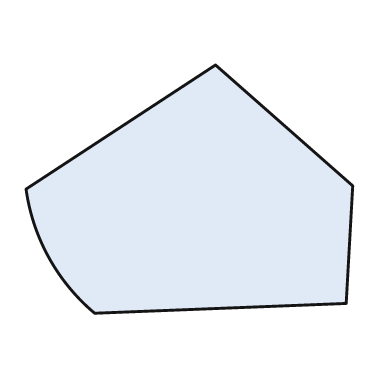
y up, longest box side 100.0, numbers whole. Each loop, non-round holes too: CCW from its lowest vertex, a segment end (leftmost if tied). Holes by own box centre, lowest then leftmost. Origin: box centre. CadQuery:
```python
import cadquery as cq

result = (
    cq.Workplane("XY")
    .moveTo(-29.0, -38.0)
    .lineTo(48.0, -35.0)
    .lineTo(50.0, 1.0)
    .lineTo(8.0, 38.0)
    .lineTo(-50.0, 0.0)
    .threePointArc((-43.0, -21.0), (-29.0, -38.0))
    .close()
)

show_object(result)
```